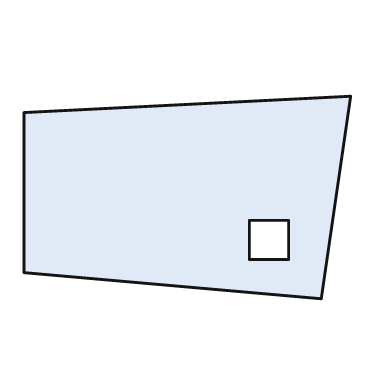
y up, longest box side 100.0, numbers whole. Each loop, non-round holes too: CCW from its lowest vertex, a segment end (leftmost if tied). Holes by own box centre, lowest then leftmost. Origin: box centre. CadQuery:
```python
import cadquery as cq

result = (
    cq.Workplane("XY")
    .moveTo(41.0, -31.0)
    .lineTo(50.0, 31.0)
    .lineTo(-50.0, 26.0)
    .lineTo(-50.0, -23.0)
    .close()
    .moveTo(19.0, -19.0)
    .lineTo(31.0, -19.0)
    .lineTo(31.0, -7.0)
    .lineTo(19.0, -7.0)
    .close()
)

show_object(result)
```